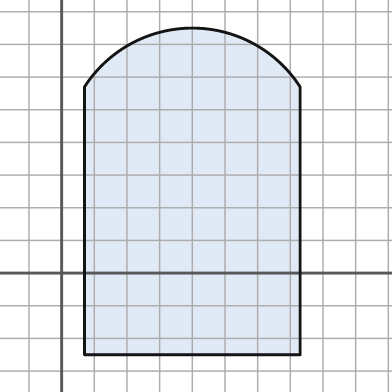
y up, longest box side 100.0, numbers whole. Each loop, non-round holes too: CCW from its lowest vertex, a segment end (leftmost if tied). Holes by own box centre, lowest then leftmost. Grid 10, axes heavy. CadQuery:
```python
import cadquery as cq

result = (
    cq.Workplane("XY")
    .moveTo(7.0, -25.0)
    .lineTo(73.0, -25.0)
    .lineTo(73.0, 57.0)
    .threePointArc((40.0, 75.0), (7.0, 57.0))
    .close()
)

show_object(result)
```